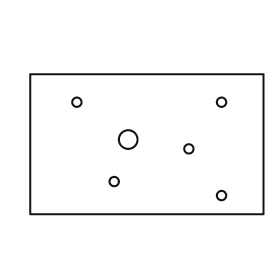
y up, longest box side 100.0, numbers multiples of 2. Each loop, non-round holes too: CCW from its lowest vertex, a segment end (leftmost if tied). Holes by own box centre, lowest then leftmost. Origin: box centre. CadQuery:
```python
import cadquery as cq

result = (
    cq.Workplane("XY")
    .moveTo(-50.0, -30.0)
    .lineTo(50.0, -30.0)
    .lineTo(50.0, 30.0)
    .lineTo(-50.0, 30.0)
    .close()
    .moveTo(32.0, -22.0)
    .circle(2.0)
    .moveTo(-14.0, -16.0)
    .circle(2.0)
    .moveTo(18.0, -2.0)
    .circle(2.0)
    .moveTo(-8.0, 2.0)
    .circle(4.0)
    .moveTo(-30.0, 18.0)
    .circle(2.0)
    .moveTo(32.0, 18.0)
    .circle(2.0)
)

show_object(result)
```